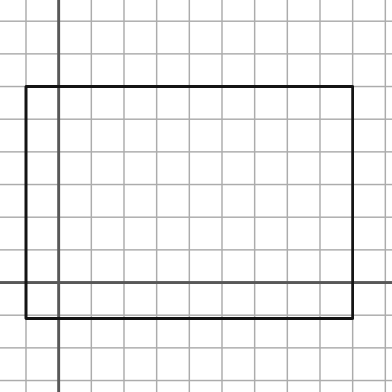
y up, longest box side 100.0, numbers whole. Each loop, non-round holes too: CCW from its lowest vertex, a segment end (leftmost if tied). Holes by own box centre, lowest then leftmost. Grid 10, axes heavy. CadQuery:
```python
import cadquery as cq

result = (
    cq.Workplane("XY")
    .moveTo(-10.0, -11.0)
    .lineTo(90.0, -11.0)
    .lineTo(90.0, 60.0)
    .lineTo(-10.0, 60.0)
    .close()
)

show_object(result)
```